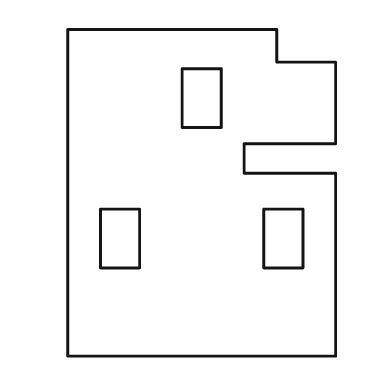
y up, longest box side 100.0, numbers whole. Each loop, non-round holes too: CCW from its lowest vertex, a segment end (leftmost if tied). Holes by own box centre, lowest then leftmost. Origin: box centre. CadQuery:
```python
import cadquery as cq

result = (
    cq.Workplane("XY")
    .moveTo(-41.0, -50.0)
    .lineTo(41.0, -50.0)
    .lineTo(41.0, 6.0)
    .lineTo(13.0, 6.0)
    .lineTo(13.0, 15.0)
    .lineTo(41.0, 15.0)
    .lineTo(41.0, 40.0)
    .lineTo(23.0, 40.0)
    .lineTo(23.0, 50.0)
    .lineTo(-41.0, 50.0)
    .close()
    .moveTo(-31.0, -23.0)
    .lineTo(-19.0, -23.0)
    .lineTo(-19.0, -5.0)
    .lineTo(-31.0, -5.0)
    .close()
    .moveTo(19.0, -23.0)
    .lineTo(31.0, -23.0)
    .lineTo(31.0, -5.0)
    .lineTo(19.0, -5.0)
    .close()
    .moveTo(-6.0, 20.0)
    .lineTo(6.0, 20.0)
    .lineTo(6.0, 38.0)
    .lineTo(-6.0, 38.0)
    .close()
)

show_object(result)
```